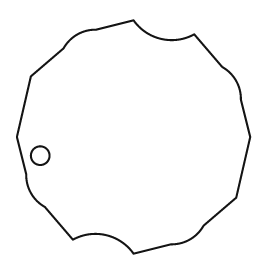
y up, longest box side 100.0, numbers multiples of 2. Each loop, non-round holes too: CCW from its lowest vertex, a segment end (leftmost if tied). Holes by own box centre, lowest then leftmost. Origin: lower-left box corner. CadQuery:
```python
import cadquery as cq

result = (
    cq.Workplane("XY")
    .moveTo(50.0, 0.0)
    .lineTo(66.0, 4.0)
    .threePointArc((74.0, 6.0), (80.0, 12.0))
    .lineTo(94.0, 24.0)
    .lineTo(100.0, 50.0)
    .lineTo(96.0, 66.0)
    .threePointArc((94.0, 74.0), (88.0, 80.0))
    .lineTo(76.0, 94.0)
    .threePointArc((62.0, 92.0), (50.0, 100.0))
    .lineTo(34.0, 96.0)
    .threePointArc((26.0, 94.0), (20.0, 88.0))
    .lineTo(6.0, 76.0)
    .lineTo(0.0, 50.0)
    .lineTo(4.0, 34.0)
    .threePointArc((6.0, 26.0), (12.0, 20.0))
    .lineTo(24.0, 6.0)
    .threePointArc((38.0, 8.0), (50.0, 0.0))
    .close()
    .moveTo(10.0, 42.0)
    .circle(4.0)
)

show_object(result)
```